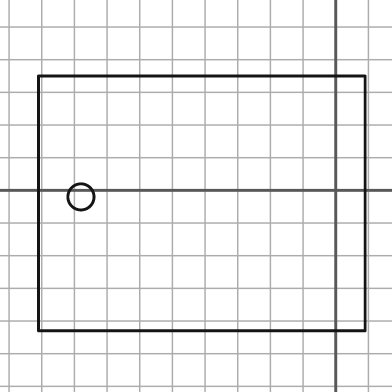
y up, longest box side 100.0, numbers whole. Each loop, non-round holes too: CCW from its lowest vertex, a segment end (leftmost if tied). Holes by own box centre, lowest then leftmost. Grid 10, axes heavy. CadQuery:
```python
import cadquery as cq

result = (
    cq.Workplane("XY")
    .moveTo(-91.0, -43.0)
    .lineTo(9.0, -43.0)
    .lineTo(9.0, 35.0)
    .lineTo(-91.0, 35.0)
    .close()
    .moveTo(-78.0, -2.0)
    .circle(4.0)
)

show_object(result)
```